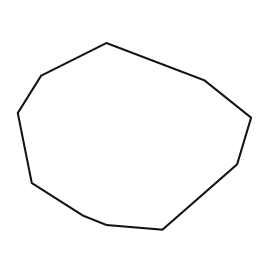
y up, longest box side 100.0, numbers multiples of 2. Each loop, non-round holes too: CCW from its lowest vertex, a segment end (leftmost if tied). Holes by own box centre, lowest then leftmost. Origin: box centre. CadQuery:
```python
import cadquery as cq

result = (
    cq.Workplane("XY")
    .moveTo(12.0, -40.0)
    .lineTo(44.0, -12.0)
    .lineTo(50.0, 8.0)
    .lineTo(30.0, 24.0)
    .lineTo(-12.0, 40.0)
    .lineTo(-40.0, 26.0)
    .lineTo(-50.0, 10.0)
    .lineTo(-44.0, -20.0)
    .lineTo(-22.0, -34.0)
    .lineTo(-12.0, -38.0)
    .close()
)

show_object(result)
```